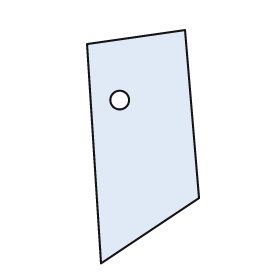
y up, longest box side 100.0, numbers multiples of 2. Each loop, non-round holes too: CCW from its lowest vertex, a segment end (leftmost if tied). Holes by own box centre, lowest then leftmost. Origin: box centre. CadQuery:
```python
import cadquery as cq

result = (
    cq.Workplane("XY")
    .moveTo(-18.0, -50.0)
    .lineTo(24.0, -22.0)
    .lineTo(18.0, 50.0)
    .lineTo(-24.0, 44.0)
    .close()
    .moveTo(-10.0, 20.0)
    .circle(4.0)
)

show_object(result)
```